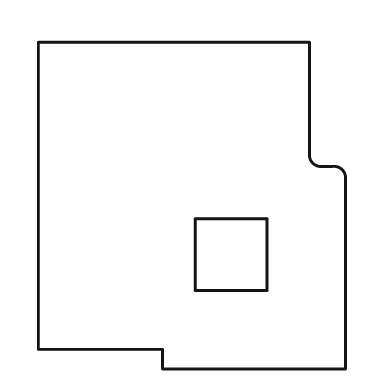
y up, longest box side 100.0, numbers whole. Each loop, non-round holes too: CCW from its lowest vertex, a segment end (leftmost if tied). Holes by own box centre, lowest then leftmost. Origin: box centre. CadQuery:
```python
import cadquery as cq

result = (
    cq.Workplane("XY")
    .moveTo(-9.0, -50.0)
    .lineTo(47.0, -50.0)
    .lineTo(47.0, 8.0)
    .threePointArc((46.0, 11.0), (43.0, 12.0))
    .lineTo(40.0, 12.0)
    .threePointArc((37.0, 13.0), (36.0, 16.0))
    .lineTo(36.0, 50.0)
    .lineTo(-47.0, 50.0)
    .lineTo(-47.0, -44.0)
    .lineTo(-9.0, -44.0)
    .close()
    .moveTo(1.0, -26.0)
    .lineTo(23.0, -26.0)
    .lineTo(23.0, -4.0)
    .lineTo(1.0, -4.0)
    .close()
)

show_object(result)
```